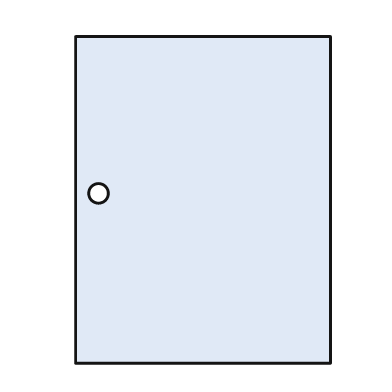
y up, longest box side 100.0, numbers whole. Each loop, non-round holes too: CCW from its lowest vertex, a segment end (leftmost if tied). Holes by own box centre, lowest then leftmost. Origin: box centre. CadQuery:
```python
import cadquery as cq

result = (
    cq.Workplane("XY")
    .moveTo(-39.0, -50.0)
    .lineTo(39.0, -50.0)
    .lineTo(39.0, 50.0)
    .lineTo(-39.0, 50.0)
    .close()
    .moveTo(-32.0, 2.0)
    .circle(3.0)
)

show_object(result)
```